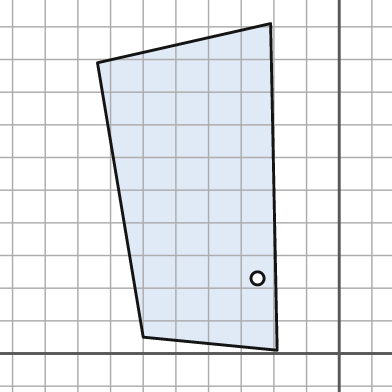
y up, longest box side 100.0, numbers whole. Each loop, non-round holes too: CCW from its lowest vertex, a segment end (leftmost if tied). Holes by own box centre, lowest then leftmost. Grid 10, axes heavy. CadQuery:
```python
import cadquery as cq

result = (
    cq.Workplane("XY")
    .moveTo(-19.0, 1.0)
    .lineTo(-21.0, 101.0)
    .lineTo(-74.0, 89.0)
    .lineTo(-60.0, 5.0)
    .close()
    .moveTo(-25.0, 23.0)
    .circle(2.0)
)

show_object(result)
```